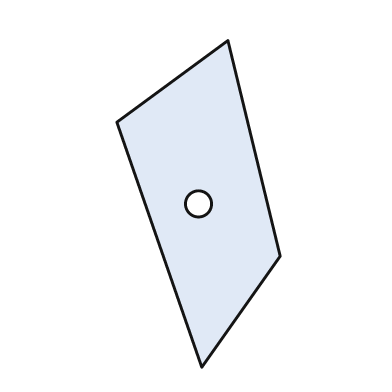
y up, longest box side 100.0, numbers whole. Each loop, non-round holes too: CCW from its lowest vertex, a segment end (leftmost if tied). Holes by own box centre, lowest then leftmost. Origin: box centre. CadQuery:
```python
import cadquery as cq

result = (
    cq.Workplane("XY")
    .moveTo(1.0, -50.0)
    .lineTo(25.0, -16.0)
    .lineTo(9.0, 50.0)
    .lineTo(-25.0, 25.0)
    .close()
    .moveTo(0.0, 0.0)
    .circle(4.0)
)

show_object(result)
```